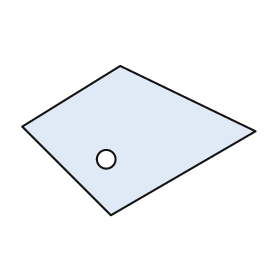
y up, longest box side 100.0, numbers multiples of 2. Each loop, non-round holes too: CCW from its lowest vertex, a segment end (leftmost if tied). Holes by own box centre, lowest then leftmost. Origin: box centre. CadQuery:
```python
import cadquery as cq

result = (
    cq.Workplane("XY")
    .moveTo(-12.0, -32.0)
    .lineTo(50.0, 4.0)
    .lineTo(-8.0, 32.0)
    .lineTo(-50.0, 6.0)
    .close()
    .moveTo(-14.0, -8.0)
    .circle(4.0)
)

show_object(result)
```